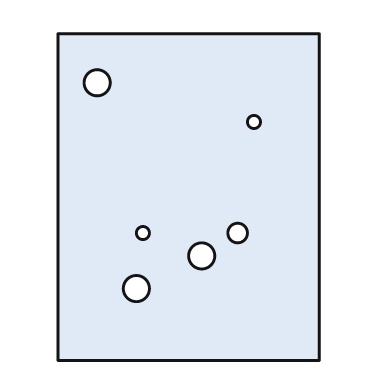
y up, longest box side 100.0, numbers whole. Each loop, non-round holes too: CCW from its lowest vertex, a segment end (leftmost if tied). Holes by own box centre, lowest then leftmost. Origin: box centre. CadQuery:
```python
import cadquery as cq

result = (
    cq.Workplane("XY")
    .moveTo(-40.0, -50.0)
    .lineTo(40.0, -50.0)
    .lineTo(40.0, 50.0)
    .lineTo(-40.0, 50.0)
    .close()
    .moveTo(-16.0, -28.0)
    .circle(4.0)
    .moveTo(4.0, -18.0)
    .circle(4.0)
    .moveTo(-14.0, -11.0)
    .circle(2.0)
    .moveTo(15.0, -11.0)
    .circle(3.0)
    .moveTo(20.0, 23.0)
    .circle(2.0)
    .moveTo(-28.0, 35.0)
    .circle(4.0)
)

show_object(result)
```